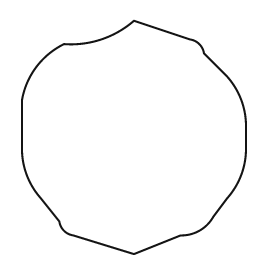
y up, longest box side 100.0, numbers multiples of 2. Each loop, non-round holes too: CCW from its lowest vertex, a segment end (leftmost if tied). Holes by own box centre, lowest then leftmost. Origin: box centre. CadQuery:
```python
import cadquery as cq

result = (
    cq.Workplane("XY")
    .moveTo(0.0, -50.0)
    .lineTo(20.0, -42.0)
    .threePointArc((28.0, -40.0), (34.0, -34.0))
    .lineTo(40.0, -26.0)
    .threePointArc((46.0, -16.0), (48.0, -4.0))
    .lineTo(48.0, 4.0)
    .threePointArc((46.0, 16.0), (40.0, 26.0))
    .lineTo(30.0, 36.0)
    .threePointArc((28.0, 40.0), (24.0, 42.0))
    .lineTo(0.0, 50.0)
    .threePointArc((-14.0, 42.0), (-30.0, 40.0))
    .threePointArc((-42.0, 30.0), (-48.0, 16.0))
    .lineTo(-48.0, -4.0)
    .threePointArc((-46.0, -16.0), (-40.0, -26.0))
    .lineTo(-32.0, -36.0)
    .threePointArc((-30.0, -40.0), (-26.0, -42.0))
    .close()
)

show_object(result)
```